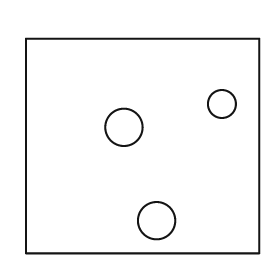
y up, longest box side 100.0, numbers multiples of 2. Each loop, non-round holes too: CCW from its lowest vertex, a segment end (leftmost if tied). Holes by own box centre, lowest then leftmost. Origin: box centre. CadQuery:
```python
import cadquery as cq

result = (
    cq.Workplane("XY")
    .moveTo(-50.0, -46.0)
    .lineTo(50.0, -46.0)
    .lineTo(50.0, 46.0)
    .lineTo(-50.0, 46.0)
    .close()
    .moveTo(6.0, -32.0)
    .circle(8.0)
    .moveTo(-8.0, 8.0)
    .circle(8.0)
    .moveTo(34.0, 18.0)
    .circle(6.0)
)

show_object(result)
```